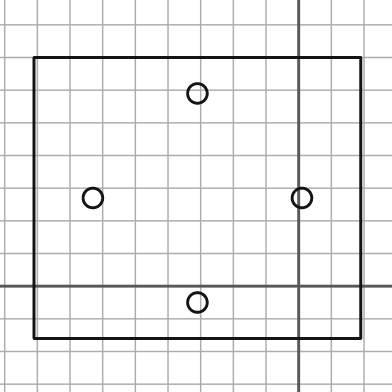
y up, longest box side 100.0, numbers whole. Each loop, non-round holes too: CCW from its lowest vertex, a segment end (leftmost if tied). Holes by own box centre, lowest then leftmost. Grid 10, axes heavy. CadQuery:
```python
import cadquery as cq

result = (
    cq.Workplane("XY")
    .moveTo(-81.0, -16.0)
    .lineTo(19.0, -16.0)
    .lineTo(19.0, 70.0)
    .lineTo(-81.0, 70.0)
    .close()
    .moveTo(-31.0, -5.0)
    .circle(3.0)
    .moveTo(-63.0, 27.0)
    .circle(3.0)
    .moveTo(1.0, 27.0)
    .circle(3.0)
    .moveTo(-31.0, 59.0)
    .circle(3.0)
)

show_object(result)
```